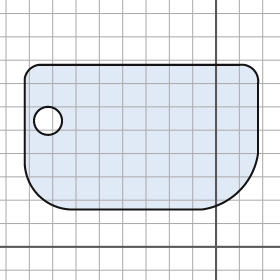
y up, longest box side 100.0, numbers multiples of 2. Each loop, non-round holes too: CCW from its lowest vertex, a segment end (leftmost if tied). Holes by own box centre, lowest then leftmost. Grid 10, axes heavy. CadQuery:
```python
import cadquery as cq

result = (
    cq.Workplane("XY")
    .moveTo(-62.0, 16.0)
    .lineTo(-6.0, 16.0)
    .threePointArc((10.0, 24.0), (18.0, 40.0))
    .lineTo(18.0, 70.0)
    .threePointArc((16.0, 76.0), (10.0, 78.0))
    .lineTo(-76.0, 78.0)
    .threePointArc((-80.0, 76.0), (-82.0, 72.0))
    .lineTo(-82.0, 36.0)
    .threePointArc((-76.0, 22.0), (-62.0, 16.0))
    .close()
    .moveTo(-72.0, 54.0)
    .circle(6.0)
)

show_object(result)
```